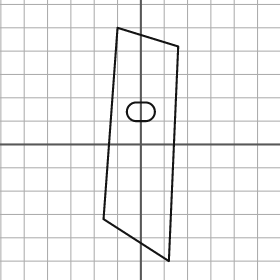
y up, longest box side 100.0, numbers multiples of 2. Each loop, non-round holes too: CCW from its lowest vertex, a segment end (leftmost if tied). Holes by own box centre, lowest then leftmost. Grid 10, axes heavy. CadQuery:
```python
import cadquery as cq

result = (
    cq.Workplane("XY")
    .moveTo(12.0, -50.0)
    .lineTo(16.0, 42.0)
    .lineTo(-10.0, 50.0)
    .lineTo(-16.0, -32.0)
    .close()
    .moveTo(-2.0, 10.0)
    .lineTo(2.0, 10.0)
    .threePointArc((6.0, 14.0), (2.0, 18.0))
    .lineTo(-2.0, 18.0)
    .threePointArc((-6.0, 14.0), (-2.0, 10.0))
    .close()
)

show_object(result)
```